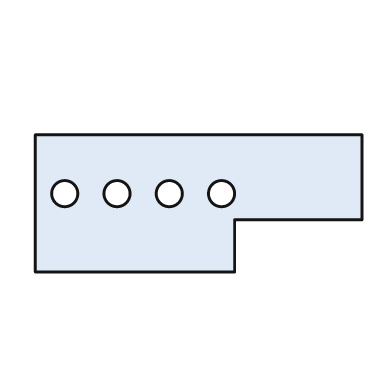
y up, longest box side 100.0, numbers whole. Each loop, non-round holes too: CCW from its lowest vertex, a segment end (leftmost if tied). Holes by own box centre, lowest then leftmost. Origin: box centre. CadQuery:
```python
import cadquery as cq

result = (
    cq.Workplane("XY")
    .moveTo(-50.0, -21.0)
    .lineTo(11.0, -21.0)
    .lineTo(11.0, -5.0)
    .lineTo(50.0, -5.0)
    .lineTo(50.0, 21.0)
    .lineTo(-50.0, 21.0)
    .close()
    .moveTo(-41.0, 3.0)
    .circle(4.0)
    .moveTo(-25.0, 3.0)
    .circle(4.0)
    .moveTo(-9.0, 3.0)
    .circle(4.0)
    .moveTo(7.0, 3.0)
    .circle(4.0)
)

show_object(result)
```